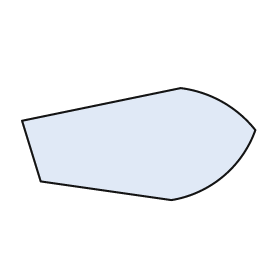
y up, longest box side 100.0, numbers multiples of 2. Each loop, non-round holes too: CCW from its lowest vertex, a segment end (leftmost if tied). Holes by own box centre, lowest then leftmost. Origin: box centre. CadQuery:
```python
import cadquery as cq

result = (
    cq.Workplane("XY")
    .moveTo(14.0, -24.0)
    .threePointArc((36.0, -14.0), (50.0, 6.0))
    .threePointArc((36.0, 18.0), (18.0, 24.0))
    .lineTo(-50.0, 10.0)
    .lineTo(-42.0, -16.0)
    .close()
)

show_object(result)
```